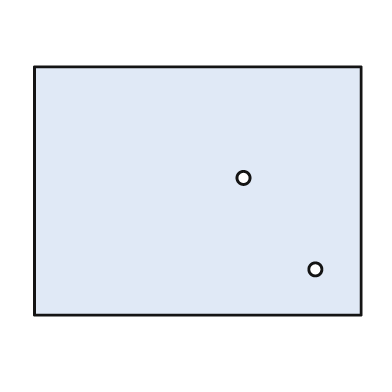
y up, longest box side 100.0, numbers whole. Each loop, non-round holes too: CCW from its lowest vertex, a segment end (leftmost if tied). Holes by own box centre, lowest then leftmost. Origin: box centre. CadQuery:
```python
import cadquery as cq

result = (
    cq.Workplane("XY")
    .moveTo(-50.0, -38.0)
    .lineTo(50.0, -38.0)
    .lineTo(50.0, 38.0)
    .lineTo(-50.0, 38.0)
    .close()
    .moveTo(36.0, -24.0)
    .circle(2.0)
    .moveTo(14.0, 4.0)
    .circle(2.0)
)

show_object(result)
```